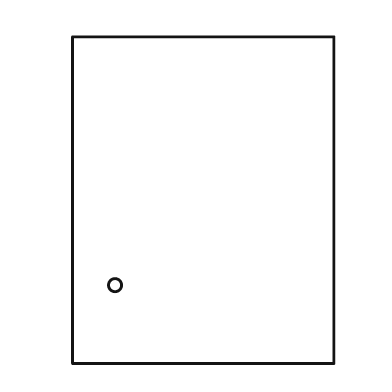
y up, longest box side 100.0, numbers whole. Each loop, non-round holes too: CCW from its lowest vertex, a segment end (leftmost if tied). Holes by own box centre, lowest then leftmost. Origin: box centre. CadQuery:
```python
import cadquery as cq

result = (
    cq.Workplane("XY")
    .moveTo(-40.0, -50.0)
    .lineTo(40.0, -50.0)
    .lineTo(40.0, 50.0)
    .lineTo(-40.0, 50.0)
    .close()
    .moveTo(-27.0, -26.0)
    .circle(2.0)
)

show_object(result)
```